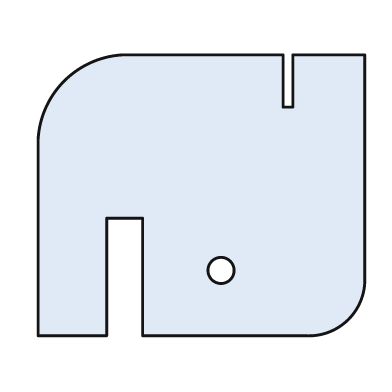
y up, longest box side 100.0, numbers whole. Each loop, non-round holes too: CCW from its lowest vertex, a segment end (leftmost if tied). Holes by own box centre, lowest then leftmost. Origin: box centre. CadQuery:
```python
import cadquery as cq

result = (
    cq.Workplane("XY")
    .moveTo(-50.0, -43.0)
    .lineTo(-29.0, -43.0)
    .lineTo(-29.0, -7.0)
    .lineTo(-18.0, -7.0)
    .lineTo(-18.0, -43.0)
    .lineTo(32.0, -43.0)
    .threePointArc((45.0, -38.0), (50.0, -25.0))
    .lineTo(50.0, 43.0)
    .lineTo(28.0, 43.0)
    .lineTo(28.0, 27.0)
    .lineTo(25.0, 27.0)
    .lineTo(25.0, 43.0)
    .lineTo(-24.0, 43.0)
    .threePointArc((-42.0, 35.0), (-50.0, 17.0))
    .close()
    .moveTo(6.0, -23.0)
    .circle(4.0)
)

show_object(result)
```